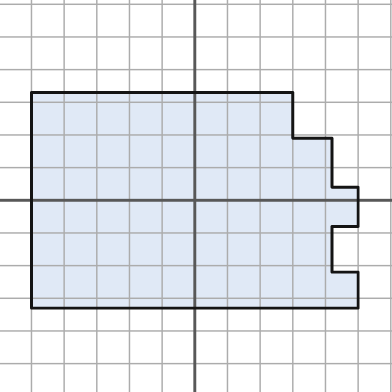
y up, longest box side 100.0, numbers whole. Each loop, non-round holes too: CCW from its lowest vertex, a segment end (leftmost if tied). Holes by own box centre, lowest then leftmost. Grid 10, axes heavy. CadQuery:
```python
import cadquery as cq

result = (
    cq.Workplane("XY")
    .moveTo(-50.0, -33.0)
    .lineTo(50.0, -33.0)
    .lineTo(50.0, -22.0)
    .lineTo(42.0, -22.0)
    .lineTo(42.0, -8.0)
    .lineTo(50.0, -8.0)
    .lineTo(50.0, 4.0)
    .lineTo(42.0, 4.0)
    .lineTo(42.0, 19.0)
    .lineTo(30.0, 19.0)
    .lineTo(30.0, 33.0)
    .lineTo(-50.0, 33.0)
    .close()
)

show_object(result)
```